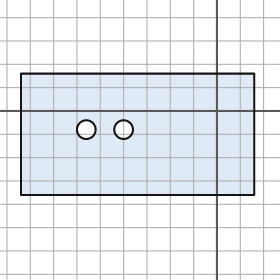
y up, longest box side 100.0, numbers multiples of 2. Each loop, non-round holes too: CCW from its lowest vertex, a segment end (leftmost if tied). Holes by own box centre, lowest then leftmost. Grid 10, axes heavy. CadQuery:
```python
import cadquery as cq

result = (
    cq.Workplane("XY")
    .moveTo(-84.0, -36.0)
    .lineTo(16.0, -36.0)
    .lineTo(16.0, 16.0)
    .lineTo(-84.0, 16.0)
    .close()
    .moveTo(-56.0, -8.0)
    .circle(4.0)
    .moveTo(-40.0, -8.0)
    .circle(4.0)
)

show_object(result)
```